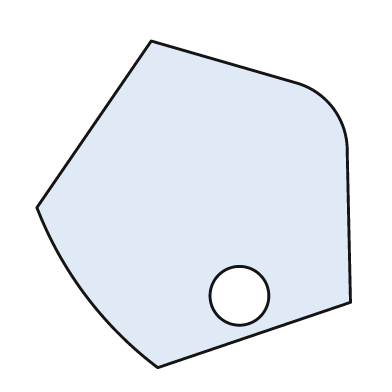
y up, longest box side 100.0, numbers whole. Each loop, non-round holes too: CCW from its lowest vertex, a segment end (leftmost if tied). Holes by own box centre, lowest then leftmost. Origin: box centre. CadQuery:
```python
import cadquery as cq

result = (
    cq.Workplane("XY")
    .moveTo(-11.0, -50.0)
    .lineTo(48.0, -30.0)
    .lineTo(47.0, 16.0)
    .threePointArc((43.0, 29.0), (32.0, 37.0))
    .lineTo(-13.0, 50.0)
    .lineTo(-48.0, -1.0)
    .threePointArc((-33.0, -28.0), (-11.0, -50.0))
    .close()
    .moveTo(14.0, -28.0)
    .circle(9.0)
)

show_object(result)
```